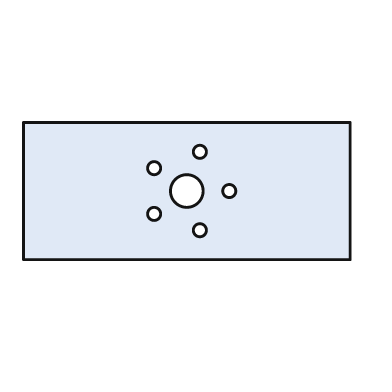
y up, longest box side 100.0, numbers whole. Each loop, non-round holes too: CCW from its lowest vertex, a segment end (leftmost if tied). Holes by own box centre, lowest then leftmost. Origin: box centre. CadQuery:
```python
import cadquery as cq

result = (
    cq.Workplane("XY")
    .moveTo(-50.0, -21.0)
    .lineTo(50.0, -21.0)
    .lineTo(50.0, 21.0)
    .lineTo(-50.0, 21.0)
    .close()
    .moveTo(4.0, -12.0)
    .circle(2.0)
    .moveTo(-10.0, -7.0)
    .circle(2.0)
    .moveTo(0.0, 0.0)
    .circle(5.0)
    .moveTo(13.0, 0.0)
    .circle(2.0)
    .moveTo(-10.0, 7.0)
    .circle(2.0)
    .moveTo(4.0, 12.0)
    .circle(2.0)
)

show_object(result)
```